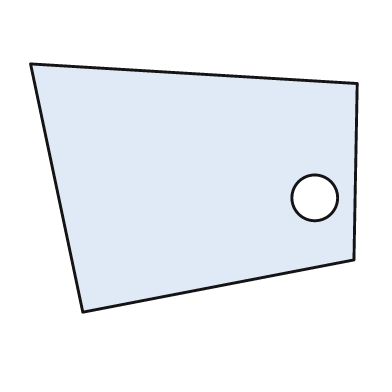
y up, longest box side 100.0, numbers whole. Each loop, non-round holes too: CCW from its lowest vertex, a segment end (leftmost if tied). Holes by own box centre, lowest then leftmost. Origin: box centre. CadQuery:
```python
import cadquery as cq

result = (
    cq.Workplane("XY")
    .moveTo(-34.0, -38.0)
    .lineTo(49.0, -22.0)
    .lineTo(50.0, 32.0)
    .lineTo(-50.0, 38.0)
    .close()
    .moveTo(37.0, -3.0)
    .circle(7.0)
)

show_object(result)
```